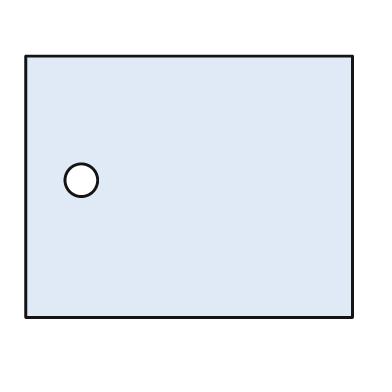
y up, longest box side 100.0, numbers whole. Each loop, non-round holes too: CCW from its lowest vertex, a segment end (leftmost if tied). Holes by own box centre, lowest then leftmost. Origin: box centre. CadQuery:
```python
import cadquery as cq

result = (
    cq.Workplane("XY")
    .moveTo(-50.0, -40.0)
    .lineTo(50.0, -40.0)
    .lineTo(50.0, 40.0)
    .lineTo(-50.0, 40.0)
    .close()
    .moveTo(-33.0, 2.0)
    .circle(5.0)
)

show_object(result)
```